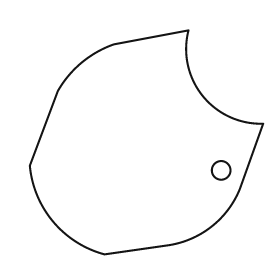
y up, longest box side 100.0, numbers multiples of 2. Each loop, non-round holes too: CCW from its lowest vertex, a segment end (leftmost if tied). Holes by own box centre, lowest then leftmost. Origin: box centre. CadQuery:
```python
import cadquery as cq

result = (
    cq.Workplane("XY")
    .moveTo(-18.0, -48.0)
    .lineTo(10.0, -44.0)
    .threePointArc((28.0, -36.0), (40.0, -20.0))
    .lineTo(50.0, 8.0)
    .threePointArc((24.0, 20.0), (18.0, 48.0))
    .lineTo(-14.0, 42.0)
    .threePointArc((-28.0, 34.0), (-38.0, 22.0))
    .lineTo(-50.0, -10.0)
    .threePointArc((-40.0, -34.0), (-18.0, -48.0))
    .close()
    .moveTo(32.0, -12.0)
    .circle(4.0)
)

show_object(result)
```